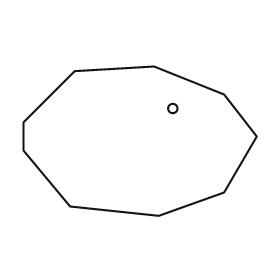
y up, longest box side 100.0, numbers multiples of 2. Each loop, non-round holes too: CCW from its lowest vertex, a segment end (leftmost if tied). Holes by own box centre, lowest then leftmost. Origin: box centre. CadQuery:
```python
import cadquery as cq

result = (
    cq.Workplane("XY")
    .moveTo(8.0, -32.0)
    .lineTo(36.0, -22.0)
    .lineTo(50.0, 2.0)
    .lineTo(36.0, 20.0)
    .lineTo(6.0, 32.0)
    .lineTo(-28.0, 30.0)
    .lineTo(-50.0, 8.0)
    .lineTo(-50.0, -4.0)
    .lineTo(-30.0, -28.0)
    .close()
    .moveTo(14.0, 14.0)
    .circle(2.0)
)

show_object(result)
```